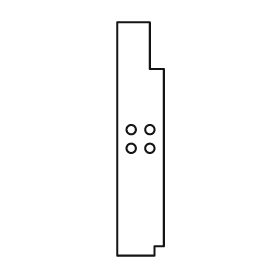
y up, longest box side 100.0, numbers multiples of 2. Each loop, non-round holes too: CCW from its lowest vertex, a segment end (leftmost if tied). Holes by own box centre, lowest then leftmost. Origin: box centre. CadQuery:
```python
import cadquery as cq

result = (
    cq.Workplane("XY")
    .moveTo(-10.0, -50.0)
    .lineTo(6.0, -50.0)
    .lineTo(6.0, -46.0)
    .lineTo(10.0, -46.0)
    .lineTo(10.0, 30.0)
    .lineTo(4.0, 30.0)
    .lineTo(4.0, 50.0)
    .lineTo(-10.0, 50.0)
    .close()
    .moveTo(-4.0, -4.0)
    .circle(2.0)
    .moveTo(4.0, -4.0)
    .circle(2.0)
    .moveTo(-4.0, 4.0)
    .circle(2.0)
    .moveTo(4.0, 4.0)
    .circle(2.0)
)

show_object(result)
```